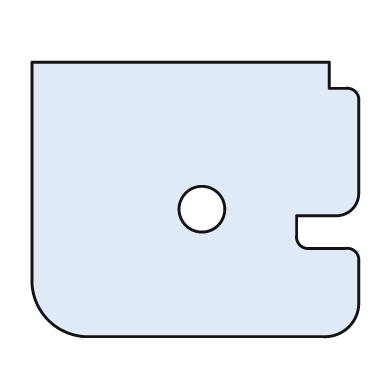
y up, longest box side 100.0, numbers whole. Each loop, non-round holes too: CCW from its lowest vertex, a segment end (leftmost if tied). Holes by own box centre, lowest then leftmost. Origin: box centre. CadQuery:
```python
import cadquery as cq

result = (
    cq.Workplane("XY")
    .moveTo(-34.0, -42.0)
    .lineTo(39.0, -42.0)
    .threePointArc((47.0, -39.0), (50.0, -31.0))
    .lineTo(50.0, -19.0)
    .threePointArc((49.0, -16.0), (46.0, -15.0))
    .lineTo(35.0, -15.0)
    .threePointArc((32.0, -14.0), (31.0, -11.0))
    .lineTo(31.0, -5.0)
    .lineTo(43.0, -5.0)
    .threePointArc((48.0, -3.0), (50.0, 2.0))
    .lineTo(50.0, 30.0)
    .threePointArc((49.0, 33.0), (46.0, 34.0))
    .lineTo(41.0, 34.0)
    .lineTo(41.0, 42.0)
    .lineTo(-50.0, 42.0)
    .lineTo(-50.0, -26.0)
    .threePointArc((-45.0, -37.0), (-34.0, -42.0))
    .close()
    .moveTo(2.0, -3.0)
    .circle(7.0)
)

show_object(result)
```